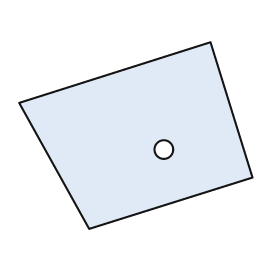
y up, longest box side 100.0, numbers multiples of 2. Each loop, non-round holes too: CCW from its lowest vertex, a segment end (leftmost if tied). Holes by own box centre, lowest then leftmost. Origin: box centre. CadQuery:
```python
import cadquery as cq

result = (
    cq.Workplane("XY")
    .moveTo(-20.0, -40.0)
    .lineTo(50.0, -18.0)
    .lineTo(32.0, 40.0)
    .lineTo(-50.0, 14.0)
    .close()
    .moveTo(12.0, -6.0)
    .circle(4.0)
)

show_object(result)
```